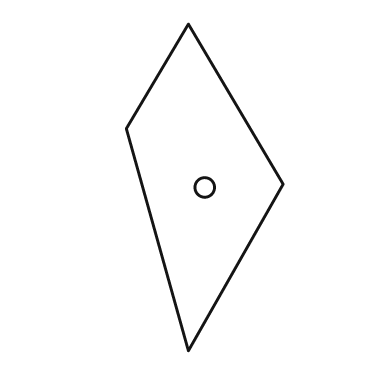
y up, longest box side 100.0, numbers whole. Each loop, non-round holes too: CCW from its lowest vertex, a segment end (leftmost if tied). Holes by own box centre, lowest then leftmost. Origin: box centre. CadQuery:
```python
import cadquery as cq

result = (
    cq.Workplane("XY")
    .moveTo(-5.0, -50.0)
    .lineTo(24.0, 1.0)
    .lineTo(-5.0, 50.0)
    .lineTo(-24.0, 18.0)
    .close()
    .moveTo(0.0, 0.0)
    .circle(3.0)
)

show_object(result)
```